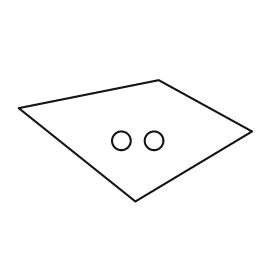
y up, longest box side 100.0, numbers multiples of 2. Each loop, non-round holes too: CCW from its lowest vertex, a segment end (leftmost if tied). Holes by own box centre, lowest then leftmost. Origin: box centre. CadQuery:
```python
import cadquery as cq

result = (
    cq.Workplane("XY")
    .moveTo(0.0, -26.0)
    .lineTo(50.0, 4.0)
    .lineTo(10.0, 26.0)
    .lineTo(-50.0, 14.0)
    .close()
    .moveTo(-6.0, 0.0)
    .circle(4.0)
    .moveTo(8.0, 0.0)
    .circle(4.0)
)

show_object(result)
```